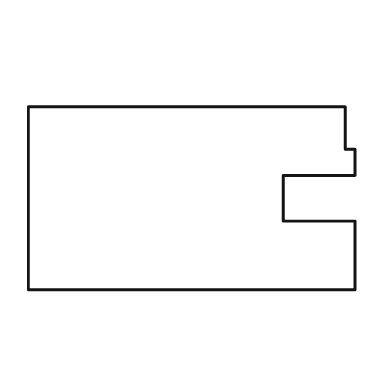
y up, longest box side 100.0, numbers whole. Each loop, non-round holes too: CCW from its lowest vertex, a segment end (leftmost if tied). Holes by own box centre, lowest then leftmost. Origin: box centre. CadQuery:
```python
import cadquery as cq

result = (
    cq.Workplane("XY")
    .moveTo(-50.0, -28.0)
    .lineTo(50.0, -28.0)
    .lineTo(50.0, -7.0)
    .lineTo(28.0, -7.0)
    .lineTo(28.0, 7.0)
    .lineTo(50.0, 7.0)
    .lineTo(50.0, 15.0)
    .lineTo(47.0, 15.0)
    .lineTo(47.0, 28.0)
    .lineTo(-50.0, 28.0)
    .close()
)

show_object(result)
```